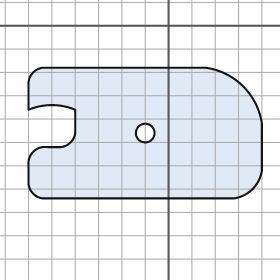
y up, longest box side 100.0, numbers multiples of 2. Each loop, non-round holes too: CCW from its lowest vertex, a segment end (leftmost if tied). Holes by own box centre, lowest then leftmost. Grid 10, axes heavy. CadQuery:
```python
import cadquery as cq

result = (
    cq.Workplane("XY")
    .moveTo(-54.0, -74.0)
    .lineTo(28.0, -74.0)
    .threePointArc((36.0, -70.0), (40.0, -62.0))
    .lineTo(40.0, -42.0)
    .threePointArc((32.0, -26.0), (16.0, -18.0))
    .lineTo(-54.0, -18.0)
    .threePointArc((-58.0, -20.0), (-60.0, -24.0))
    .lineTo(-60.0, -36.0)
    .threePointArc((-50.0, -34.0), (-40.0, -36.0))
    .lineTo(-40.0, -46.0)
    .threePointArc((-42.0, -50.0), (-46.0, -52.0))
    .lineTo(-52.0, -52.0)
    .threePointArc((-58.0, -54.0), (-60.0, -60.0))
    .lineTo(-60.0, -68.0)
    .threePointArc((-58.0, -72.0), (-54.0, -74.0))
    .close()
    .moveTo(-10.0, -46.0)
    .circle(4.0)
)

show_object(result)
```